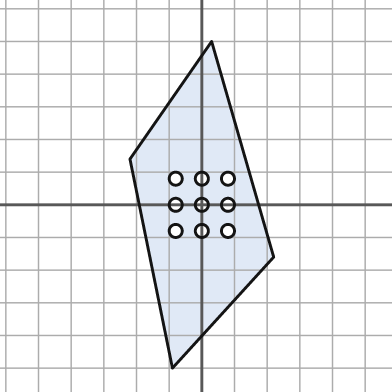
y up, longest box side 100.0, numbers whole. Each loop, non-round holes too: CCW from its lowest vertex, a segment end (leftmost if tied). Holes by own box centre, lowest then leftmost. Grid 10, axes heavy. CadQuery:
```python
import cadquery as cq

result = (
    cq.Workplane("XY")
    .moveTo(-9.0, -50.0)
    .lineTo(22.0, -16.0)
    .lineTo(3.0, 50.0)
    .lineTo(-22.0, 14.0)
    .close()
    .moveTo(-8.0, -8.0)
    .circle(2.0)
    .moveTo(0.0, -8.0)
    .circle(2.0)
    .moveTo(8.0, -8.0)
    .circle(2.0)
    .moveTo(-8.0, 0.0)
    .circle(2.0)
    .moveTo(0.0, 0.0)
    .circle(2.0)
    .moveTo(8.0, 0.0)
    .circle(2.0)
    .moveTo(-8.0, 8.0)
    .circle(2.0)
    .moveTo(0.0, 8.0)
    .circle(2.0)
    .moveTo(8.0, 8.0)
    .circle(2.0)
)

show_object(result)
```